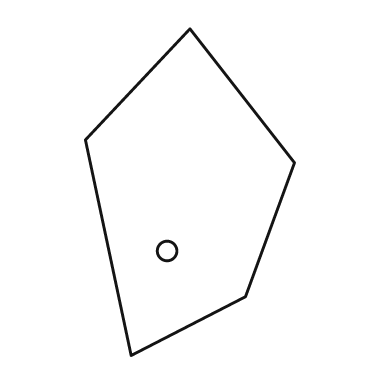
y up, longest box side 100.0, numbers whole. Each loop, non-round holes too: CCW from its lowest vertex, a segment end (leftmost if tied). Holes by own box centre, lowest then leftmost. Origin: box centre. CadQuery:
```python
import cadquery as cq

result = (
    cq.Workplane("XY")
    .moveTo(-18.0, -50.0)
    .lineTo(17.0, -32.0)
    .lineTo(32.0, 9.0)
    .lineTo(0.0, 50.0)
    .lineTo(-32.0, 16.0)
    .close()
    .moveTo(-7.0, -18.0)
    .circle(3.0)
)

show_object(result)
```